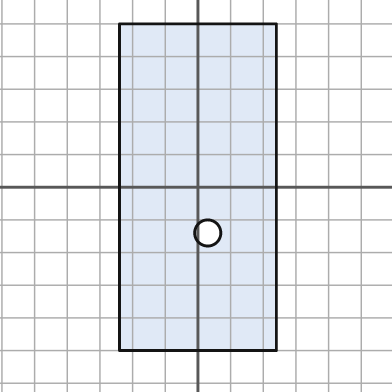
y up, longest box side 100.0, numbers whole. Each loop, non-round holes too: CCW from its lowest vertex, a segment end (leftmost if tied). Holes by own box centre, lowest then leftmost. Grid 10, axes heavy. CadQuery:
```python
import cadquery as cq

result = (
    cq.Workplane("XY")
    .moveTo(-24.0, -50.0)
    .lineTo(24.0, -50.0)
    .lineTo(24.0, 50.0)
    .lineTo(-24.0, 50.0)
    .close()
    .moveTo(3.0, -14.0)
    .circle(4.0)
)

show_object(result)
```